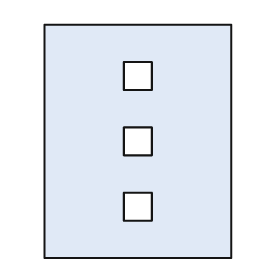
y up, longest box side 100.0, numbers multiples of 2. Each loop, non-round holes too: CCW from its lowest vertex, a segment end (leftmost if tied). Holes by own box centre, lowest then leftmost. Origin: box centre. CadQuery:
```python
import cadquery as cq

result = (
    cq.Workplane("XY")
    .moveTo(-40.0, -50.0)
    .lineTo(40.0, -50.0)
    .lineTo(40.0, 50.0)
    .lineTo(-40.0, 50.0)
    .close()
    .moveTo(-6.0, -34.0)
    .lineTo(6.0, -34.0)
    .lineTo(6.0, -22.0)
    .lineTo(-6.0, -22.0)
    .close()
    .moveTo(-6.0, -6.0)
    .lineTo(6.0, -6.0)
    .lineTo(6.0, 6.0)
    .lineTo(-6.0, 6.0)
    .close()
    .moveTo(-6.0, 22.0)
    .lineTo(6.0, 22.0)
    .lineTo(6.0, 34.0)
    .lineTo(-6.0, 34.0)
    .close()
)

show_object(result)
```